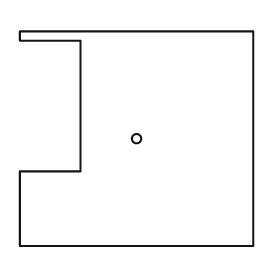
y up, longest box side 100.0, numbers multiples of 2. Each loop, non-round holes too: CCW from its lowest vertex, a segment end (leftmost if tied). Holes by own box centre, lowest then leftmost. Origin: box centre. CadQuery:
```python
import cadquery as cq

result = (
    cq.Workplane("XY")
    .moveTo(-50.0, -46.0)
    .lineTo(50.0, -46.0)
    .lineTo(50.0, 46.0)
    .lineTo(-50.0, 46.0)
    .lineTo(-50.0, 42.0)
    .lineTo(-24.0, 42.0)
    .lineTo(-24.0, -14.0)
    .lineTo(-50.0, -14.0)
    .close()
    .moveTo(0.0, 0.0)
    .circle(2.0)
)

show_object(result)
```